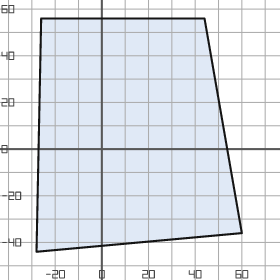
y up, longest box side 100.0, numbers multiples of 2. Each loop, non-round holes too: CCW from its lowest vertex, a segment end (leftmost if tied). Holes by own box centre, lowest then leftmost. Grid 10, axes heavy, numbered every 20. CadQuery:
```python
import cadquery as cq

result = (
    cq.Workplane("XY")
    .moveTo(-28.0, -44.0)
    .lineTo(60.0, -36.0)
    .lineTo(44.0, 56.0)
    .lineTo(-26.0, 56.0)
    .close()
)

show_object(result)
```